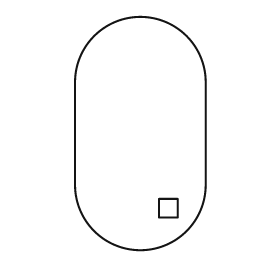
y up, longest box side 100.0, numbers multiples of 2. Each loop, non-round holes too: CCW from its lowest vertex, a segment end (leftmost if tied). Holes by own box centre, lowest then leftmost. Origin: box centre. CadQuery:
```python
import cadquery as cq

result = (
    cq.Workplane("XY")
    .moveTo(-28.0, -22.0)
    .threePointArc((0.0, -50.0), (28.0, -22.0))
    .lineTo(28.0, 22.0)
    .threePointArc((0.0, 50.0), (-28.0, 22.0))
    .close()
    .moveTo(8.0, -36.0)
    .lineTo(16.0, -36.0)
    .lineTo(16.0, -28.0)
    .lineTo(8.0, -28.0)
    .close()
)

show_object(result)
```